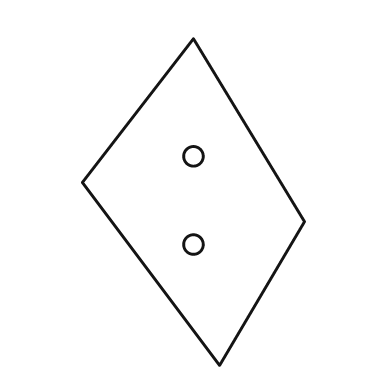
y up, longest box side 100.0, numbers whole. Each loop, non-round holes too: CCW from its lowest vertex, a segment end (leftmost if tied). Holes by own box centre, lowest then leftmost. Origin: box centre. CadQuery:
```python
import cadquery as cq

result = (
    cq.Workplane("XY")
    .moveTo(8.0, -50.0)
    .lineTo(34.0, -6.0)
    .lineTo(0.0, 50.0)
    .lineTo(-34.0, 6.0)
    .close()
    .moveTo(0.0, -13.0)
    .circle(3.0)
    .moveTo(0.0, 14.0)
    .circle(3.0)
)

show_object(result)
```